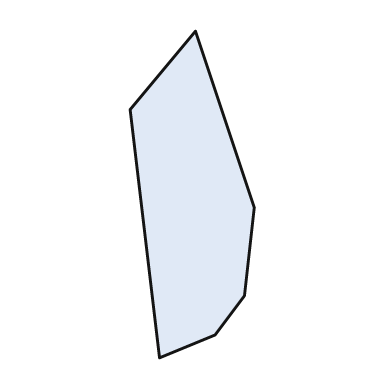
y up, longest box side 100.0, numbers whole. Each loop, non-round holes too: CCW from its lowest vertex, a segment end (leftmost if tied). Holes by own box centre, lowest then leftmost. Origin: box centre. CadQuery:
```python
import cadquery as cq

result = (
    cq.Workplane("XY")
    .moveTo(-10.0, -50.0)
    .lineTo(7.0, -43.0)
    .lineTo(16.0, -31.0)
    .lineTo(19.0, -4.0)
    .lineTo(1.0, 50.0)
    .lineTo(-19.0, 26.0)
    .close()
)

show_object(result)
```